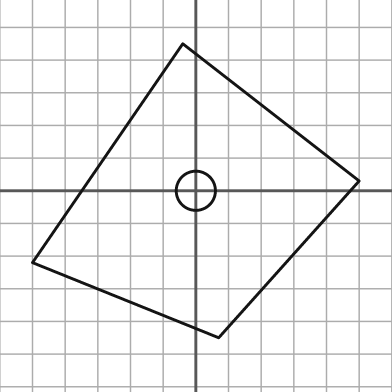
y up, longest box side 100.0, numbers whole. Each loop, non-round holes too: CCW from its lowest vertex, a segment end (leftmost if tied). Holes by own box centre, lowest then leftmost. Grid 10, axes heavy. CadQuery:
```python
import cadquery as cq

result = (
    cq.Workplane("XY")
    .moveTo(7.0, -45.0)
    .lineTo(50.0, 3.0)
    .lineTo(-4.0, 45.0)
    .lineTo(-50.0, -22.0)
    .close()
    .moveTo(0.0, 0.0)
    .circle(6.0)
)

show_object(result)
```